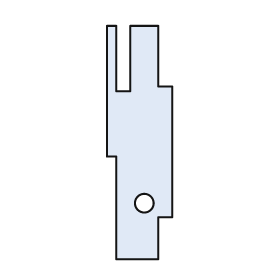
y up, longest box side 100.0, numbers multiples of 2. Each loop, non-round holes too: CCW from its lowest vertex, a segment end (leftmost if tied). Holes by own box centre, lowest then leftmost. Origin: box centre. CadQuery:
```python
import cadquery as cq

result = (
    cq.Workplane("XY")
    .moveTo(-10.0, -50.0)
    .lineTo(8.0, -50.0)
    .lineTo(8.0, -32.0)
    .lineTo(14.0, -32.0)
    .lineTo(14.0, 24.0)
    .lineTo(8.0, 24.0)
    .lineTo(8.0, 50.0)
    .lineTo(-4.0, 50.0)
    .lineTo(-4.0, 22.0)
    .lineTo(-10.0, 22.0)
    .lineTo(-10.0, 50.0)
    .lineTo(-14.0, 50.0)
    .lineTo(-14.0, -6.0)
    .lineTo(-10.0, -6.0)
    .close()
    .moveTo(2.0, -26.0)
    .circle(4.0)
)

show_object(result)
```